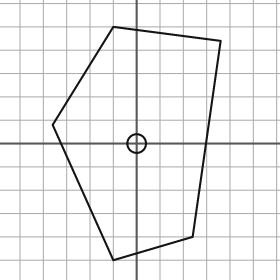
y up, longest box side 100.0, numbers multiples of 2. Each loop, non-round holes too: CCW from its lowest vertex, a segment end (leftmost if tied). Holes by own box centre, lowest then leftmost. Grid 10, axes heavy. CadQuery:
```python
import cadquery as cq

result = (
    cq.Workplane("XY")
    .moveTo(-10.0, -50.0)
    .lineTo(24.0, -40.0)
    .lineTo(36.0, 44.0)
    .lineTo(-10.0, 50.0)
    .lineTo(-36.0, 8.0)
    .close()
    .moveTo(0.0, 0.0)
    .circle(4.0)
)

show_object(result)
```